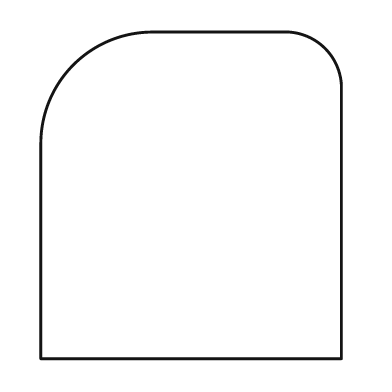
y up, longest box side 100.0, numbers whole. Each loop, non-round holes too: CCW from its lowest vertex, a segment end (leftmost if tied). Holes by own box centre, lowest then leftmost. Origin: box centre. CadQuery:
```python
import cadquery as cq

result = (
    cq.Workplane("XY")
    .moveTo(-46.0, -50.0)
    .lineTo(46.0, -50.0)
    .lineTo(46.0, 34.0)
    .threePointArc((41.0, 45.0), (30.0, 50.0))
    .lineTo(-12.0, 50.0)
    .threePointArc((-36.0, 40.0), (-46.0, 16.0))
    .close()
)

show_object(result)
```